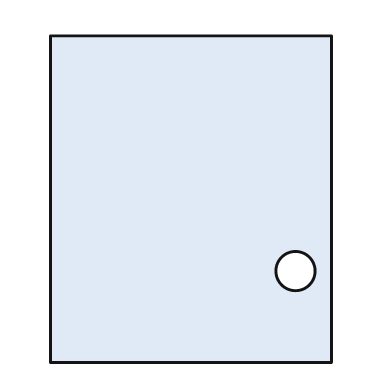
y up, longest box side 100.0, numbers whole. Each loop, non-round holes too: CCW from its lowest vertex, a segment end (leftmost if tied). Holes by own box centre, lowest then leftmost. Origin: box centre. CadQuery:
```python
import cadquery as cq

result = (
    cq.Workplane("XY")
    .moveTo(-43.0, -50.0)
    .lineTo(43.0, -50.0)
    .lineTo(43.0, 50.0)
    .lineTo(-43.0, 50.0)
    .close()
    .moveTo(32.0, -22.0)
    .circle(6.0)
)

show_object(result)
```